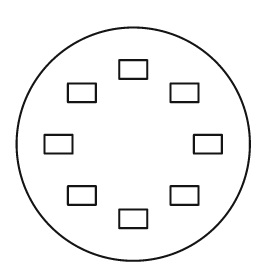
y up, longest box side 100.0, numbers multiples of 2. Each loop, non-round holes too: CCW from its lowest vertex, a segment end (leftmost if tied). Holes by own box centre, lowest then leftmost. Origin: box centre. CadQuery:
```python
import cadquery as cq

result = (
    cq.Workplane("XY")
    .moveTo(0.0, 0.0)
    .circle(50.0)
    .moveTo(-6.0, -36.0)
    .lineTo(6.0, -36.0)
    .lineTo(6.0, -28.0)
    .lineTo(-6.0, -28.0)
    .close()
    .moveTo(-28.0, -26.0)
    .lineTo(-16.0, -26.0)
    .lineTo(-16.0, -18.0)
    .lineTo(-28.0, -18.0)
    .close()
    .moveTo(16.0, -26.0)
    .lineTo(28.0, -26.0)
    .lineTo(28.0, -18.0)
    .lineTo(16.0, -18.0)
    .close()
    .moveTo(-38.0, -4.0)
    .lineTo(-26.0, -4.0)
    .lineTo(-26.0, 4.0)
    .lineTo(-38.0, 4.0)
    .close()
    .moveTo(26.0, -4.0)
    .lineTo(38.0, -4.0)
    .lineTo(38.0, 4.0)
    .lineTo(26.0, 4.0)
    .close()
    .moveTo(-28.0, 18.0)
    .lineTo(-16.0, 18.0)
    .lineTo(-16.0, 26.0)
    .lineTo(-28.0, 26.0)
    .close()
    .moveTo(16.0, 18.0)
    .lineTo(28.0, 18.0)
    .lineTo(28.0, 26.0)
    .lineTo(16.0, 26.0)
    .close()
    .moveTo(-6.0, 28.0)
    .lineTo(6.0, 28.0)
    .lineTo(6.0, 36.0)
    .lineTo(-6.0, 36.0)
    .close()
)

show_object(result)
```